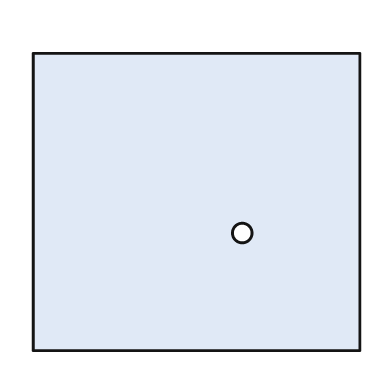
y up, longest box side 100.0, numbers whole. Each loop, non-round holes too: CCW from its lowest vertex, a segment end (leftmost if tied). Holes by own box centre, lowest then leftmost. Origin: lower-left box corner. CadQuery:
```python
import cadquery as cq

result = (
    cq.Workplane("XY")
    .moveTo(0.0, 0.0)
    .lineTo(100.0, 0.0)
    .lineTo(100.0, 91.0)
    .lineTo(0.0, 91.0)
    .close()
    .moveTo(64.0, 36.0)
    .circle(3.0)
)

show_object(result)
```